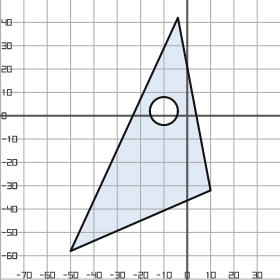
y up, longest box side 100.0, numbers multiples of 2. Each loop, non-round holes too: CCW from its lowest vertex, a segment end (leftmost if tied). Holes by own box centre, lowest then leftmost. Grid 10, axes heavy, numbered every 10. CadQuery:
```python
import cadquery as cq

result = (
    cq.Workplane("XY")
    .moveTo(-50.0, -58.0)
    .lineTo(10.0, -32.0)
    .lineTo(-4.0, 42.0)
    .close()
    .moveTo(-10.0, 2.0)
    .circle(6.0)
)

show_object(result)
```